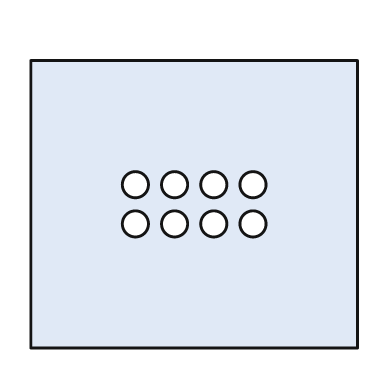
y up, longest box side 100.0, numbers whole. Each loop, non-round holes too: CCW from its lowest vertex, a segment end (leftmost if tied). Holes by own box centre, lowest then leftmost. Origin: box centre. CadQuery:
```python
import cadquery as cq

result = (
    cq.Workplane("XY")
    .moveTo(-50.0, -44.0)
    .lineTo(50.0, -44.0)
    .lineTo(50.0, 44.0)
    .lineTo(-50.0, 44.0)
    .close()
    .moveTo(-18.0, -6.0)
    .circle(4.0)
    .moveTo(-6.0, -6.0)
    .circle(4.0)
    .moveTo(6.0, -6.0)
    .circle(4.0)
    .moveTo(18.0, -6.0)
    .circle(4.0)
    .moveTo(-18.0, 6.0)
    .circle(4.0)
    .moveTo(-6.0, 6.0)
    .circle(4.0)
    .moveTo(6.0, 6.0)
    .circle(4.0)
    .moveTo(18.0, 6.0)
    .circle(4.0)
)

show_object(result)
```